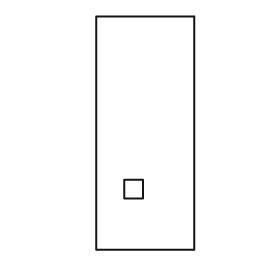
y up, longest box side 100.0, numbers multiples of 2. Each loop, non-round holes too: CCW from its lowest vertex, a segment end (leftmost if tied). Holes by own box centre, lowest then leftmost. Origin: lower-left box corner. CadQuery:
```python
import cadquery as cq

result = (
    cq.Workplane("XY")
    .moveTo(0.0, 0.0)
    .lineTo(42.0, 0.0)
    .lineTo(42.0, 100.0)
    .lineTo(0.0, 100.0)
    .close()
    .moveTo(12.0, 22.0)
    .lineTo(20.0, 22.0)
    .lineTo(20.0, 30.0)
    .lineTo(12.0, 30.0)
    .close()
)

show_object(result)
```